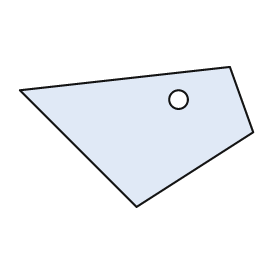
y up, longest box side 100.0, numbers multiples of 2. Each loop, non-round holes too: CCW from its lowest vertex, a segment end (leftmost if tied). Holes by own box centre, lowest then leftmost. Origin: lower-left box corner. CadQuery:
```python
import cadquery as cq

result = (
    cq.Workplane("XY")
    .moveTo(50.0, 0.0)
    .lineTo(100.0, 32.0)
    .lineTo(90.0, 60.0)
    .lineTo(0.0, 50.0)
    .close()
    .moveTo(68.0, 46.0)
    .circle(4.0)
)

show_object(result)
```